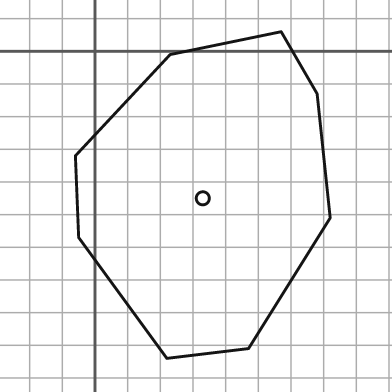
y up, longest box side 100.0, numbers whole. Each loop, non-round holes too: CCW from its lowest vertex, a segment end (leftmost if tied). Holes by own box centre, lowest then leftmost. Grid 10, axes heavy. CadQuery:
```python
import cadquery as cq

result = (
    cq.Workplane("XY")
    .moveTo(22.0, -94.0)
    .lineTo(47.0, -91.0)
    .lineTo(72.0, -51.0)
    .lineTo(68.0, -13.0)
    .lineTo(57.0, 6.0)
    .lineTo(23.0, -1.0)
    .lineTo(-6.0, -32.0)
    .lineTo(-5.0, -57.0)
    .close()
    .moveTo(33.0, -45.0)
    .circle(2.0)
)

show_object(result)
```